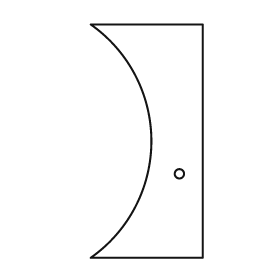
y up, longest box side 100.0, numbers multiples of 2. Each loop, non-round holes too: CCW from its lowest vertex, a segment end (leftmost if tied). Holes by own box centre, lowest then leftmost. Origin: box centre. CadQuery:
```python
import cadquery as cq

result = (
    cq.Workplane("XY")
    .moveTo(-24.0, -50.0)
    .lineTo(24.0, -50.0)
    .lineTo(24.0, 50.0)
    .lineTo(-24.0, 50.0)
    .threePointArc((2.0, 0.0), (-24.0, -50.0))
    .close()
    .moveTo(14.0, -14.0)
    .circle(2.0)
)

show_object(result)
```